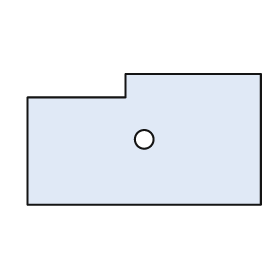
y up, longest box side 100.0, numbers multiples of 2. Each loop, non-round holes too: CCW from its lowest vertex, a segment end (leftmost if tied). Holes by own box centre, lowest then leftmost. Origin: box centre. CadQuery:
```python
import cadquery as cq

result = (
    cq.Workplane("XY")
    .moveTo(-50.0, -28.0)
    .lineTo(50.0, -28.0)
    .lineTo(50.0, 28.0)
    .lineTo(-8.0, 28.0)
    .lineTo(-8.0, 18.0)
    .lineTo(-50.0, 18.0)
    .close()
    .moveTo(0.0, 0.0)
    .circle(4.0)
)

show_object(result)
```